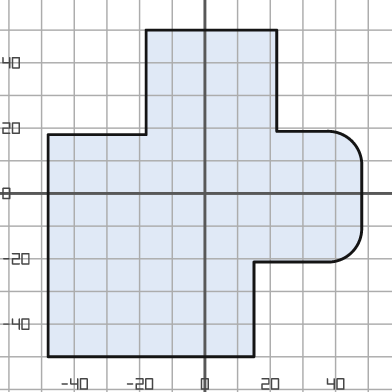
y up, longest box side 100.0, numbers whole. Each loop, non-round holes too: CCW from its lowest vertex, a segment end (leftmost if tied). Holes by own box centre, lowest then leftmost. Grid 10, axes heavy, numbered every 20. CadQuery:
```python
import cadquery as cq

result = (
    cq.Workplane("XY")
    .moveTo(-48.0, -50.0)
    .lineTo(15.0, -50.0)
    .lineTo(15.0, -21.0)
    .lineTo(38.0, -21.0)
    .threePointArc((45.0, -18.0), (48.0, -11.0))
    .lineTo(48.0, 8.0)
    .threePointArc((45.0, 16.0), (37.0, 19.0))
    .lineTo(22.0, 19.0)
    .lineTo(22.0, 50.0)
    .lineTo(-18.0, 50.0)
    .lineTo(-18.0, 18.0)
    .lineTo(-48.0, 18.0)
    .close()
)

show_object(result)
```